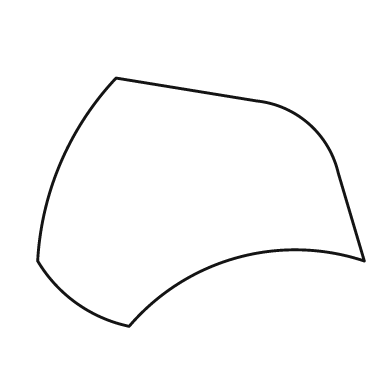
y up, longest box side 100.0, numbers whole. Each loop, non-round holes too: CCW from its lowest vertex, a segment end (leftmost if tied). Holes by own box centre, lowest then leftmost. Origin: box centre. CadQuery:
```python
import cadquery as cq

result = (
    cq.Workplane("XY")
    .moveTo(-22.0, -38.0)
    .threePointArc((11.0, -17.0), (50.0, -18.0))
    .lineTo(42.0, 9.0)
    .threePointArc((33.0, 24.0), (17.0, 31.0))
    .lineTo(-26.0, 38.0)
    .threePointArc((-43.0, 12.0), (-50.0, -18.0))
    .threePointArc((-38.0, -31.0), (-22.0, -38.0))
    .close()
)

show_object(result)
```